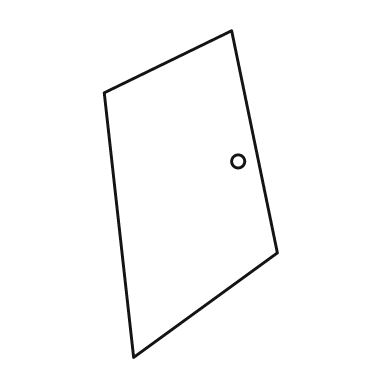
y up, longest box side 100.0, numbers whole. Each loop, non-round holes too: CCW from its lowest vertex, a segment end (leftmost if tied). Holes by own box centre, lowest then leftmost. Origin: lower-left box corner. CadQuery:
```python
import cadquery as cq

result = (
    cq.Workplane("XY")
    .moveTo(9.0, 0.0)
    .lineTo(53.0, 32.0)
    .lineTo(39.0, 100.0)
    .lineTo(0.0, 81.0)
    .close()
    .moveTo(41.0, 60.0)
    .circle(2.0)
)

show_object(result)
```